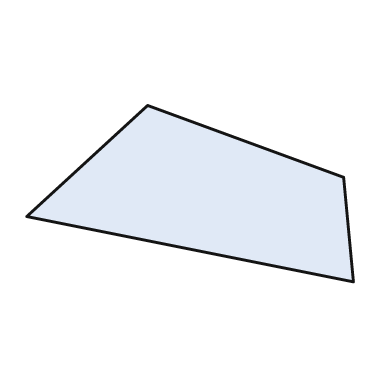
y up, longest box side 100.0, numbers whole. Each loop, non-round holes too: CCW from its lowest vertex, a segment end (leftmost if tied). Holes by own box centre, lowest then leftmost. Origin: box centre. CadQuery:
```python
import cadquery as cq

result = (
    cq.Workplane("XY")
    .moveTo(50.0, -27.0)
    .lineTo(47.0, 5.0)
    .lineTo(-13.0, 27.0)
    .lineTo(-50.0, -7.0)
    .close()
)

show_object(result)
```